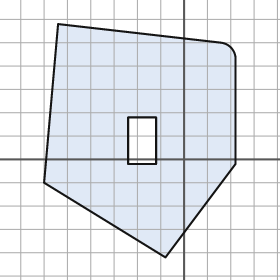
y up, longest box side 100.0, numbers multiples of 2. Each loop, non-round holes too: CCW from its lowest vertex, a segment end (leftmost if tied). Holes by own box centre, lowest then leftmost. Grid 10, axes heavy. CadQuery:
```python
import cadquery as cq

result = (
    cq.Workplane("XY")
    .moveTo(-8.0, -42.0)
    .lineTo(22.0, -2.0)
    .lineTo(22.0, 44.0)
    .threePointArc((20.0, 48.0), (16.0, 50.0))
    .lineTo(-54.0, 58.0)
    .lineTo(-60.0, -10.0)
    .close()
    .moveTo(-24.0, -2.0)
    .lineTo(-12.0, -2.0)
    .lineTo(-12.0, 18.0)
    .lineTo(-24.0, 18.0)
    .close()
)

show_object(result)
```